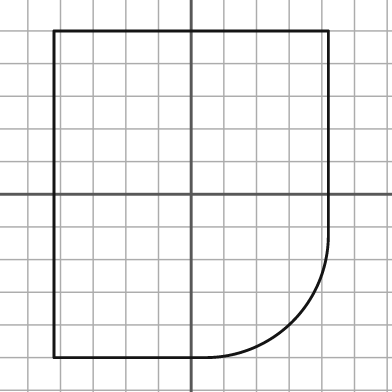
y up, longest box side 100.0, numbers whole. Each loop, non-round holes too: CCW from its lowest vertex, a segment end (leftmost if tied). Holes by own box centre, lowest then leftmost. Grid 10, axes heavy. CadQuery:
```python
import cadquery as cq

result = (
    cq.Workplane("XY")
    .moveTo(-42.0, -50.0)
    .lineTo(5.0, -50.0)
    .threePointArc((31.0, -39.0), (42.0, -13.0))
    .lineTo(42.0, 50.0)
    .lineTo(-42.0, 50.0)
    .close()
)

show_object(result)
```